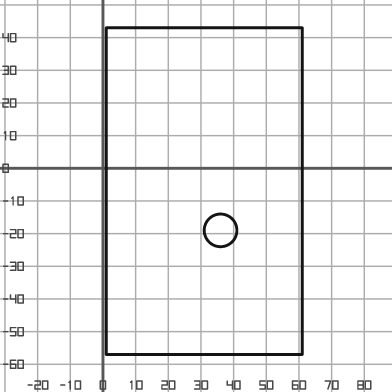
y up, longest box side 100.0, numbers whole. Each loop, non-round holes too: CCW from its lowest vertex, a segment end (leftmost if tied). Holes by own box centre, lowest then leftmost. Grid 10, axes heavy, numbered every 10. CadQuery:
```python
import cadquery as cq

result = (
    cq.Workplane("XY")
    .moveTo(1.0, -57.0)
    .lineTo(61.0, -57.0)
    .lineTo(61.0, 43.0)
    .lineTo(1.0, 43.0)
    .close()
    .moveTo(36.0, -19.0)
    .circle(5.0)
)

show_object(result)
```